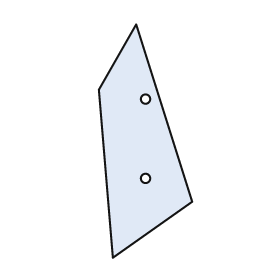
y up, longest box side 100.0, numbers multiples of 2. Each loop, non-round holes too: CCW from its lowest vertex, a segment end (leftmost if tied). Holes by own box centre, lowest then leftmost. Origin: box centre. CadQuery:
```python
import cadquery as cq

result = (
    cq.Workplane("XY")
    .moveTo(-14.0, -50.0)
    .lineTo(20.0, -26.0)
    .lineTo(-4.0, 50.0)
    .lineTo(-20.0, 22.0)
    .close()
    .moveTo(0.0, -16.0)
    .circle(2.0)
    .moveTo(0.0, 18.0)
    .circle(2.0)
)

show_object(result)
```